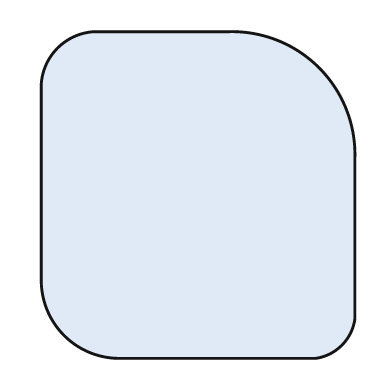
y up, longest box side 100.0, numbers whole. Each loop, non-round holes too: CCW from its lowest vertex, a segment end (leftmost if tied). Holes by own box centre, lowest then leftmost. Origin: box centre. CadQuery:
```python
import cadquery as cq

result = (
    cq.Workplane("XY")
    .moveTo(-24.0, -50.0)
    .lineTo(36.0, -50.0)
    .threePointArc((44.0, -46.0), (48.0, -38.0))
    .lineTo(48.0, 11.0)
    .threePointArc((37.0, 39.0), (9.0, 50.0))
    .lineTo(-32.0, 50.0)
    .threePointArc((-43.0, 45.0), (-48.0, 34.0))
    .lineTo(-48.0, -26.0)
    .threePointArc((-41.0, -43.0), (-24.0, -50.0))
    .close()
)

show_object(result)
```